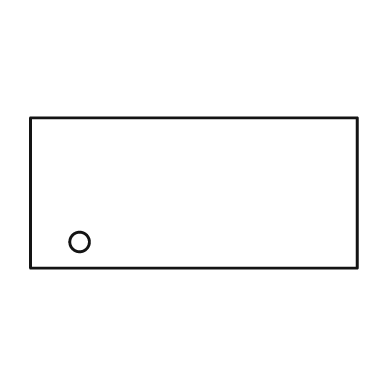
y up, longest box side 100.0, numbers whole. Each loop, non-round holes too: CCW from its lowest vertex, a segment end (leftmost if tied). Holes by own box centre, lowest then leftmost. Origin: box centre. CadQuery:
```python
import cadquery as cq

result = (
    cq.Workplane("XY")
    .moveTo(-50.0, -23.0)
    .lineTo(50.0, -23.0)
    .lineTo(50.0, 23.0)
    .lineTo(-50.0, 23.0)
    .close()
    .moveTo(-35.0, -15.0)
    .circle(3.0)
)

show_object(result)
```